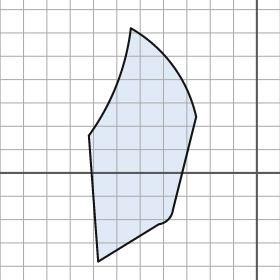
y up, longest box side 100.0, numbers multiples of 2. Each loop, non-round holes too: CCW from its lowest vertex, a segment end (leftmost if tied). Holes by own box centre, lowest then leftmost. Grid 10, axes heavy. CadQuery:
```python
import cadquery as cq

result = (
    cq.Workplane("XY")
    .moveTo(-68.0, -38.0)
    .lineTo(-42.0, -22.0)
    .threePointArc((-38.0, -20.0), (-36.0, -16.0))
    .lineTo(-26.0, 24.0)
    .threePointArc((-36.0, 46.0), (-54.0, 62.0))
    .threePointArc((-60.0, 38.0), (-72.0, 16.0))
    .close()
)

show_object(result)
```